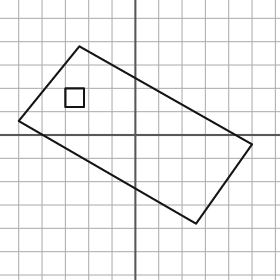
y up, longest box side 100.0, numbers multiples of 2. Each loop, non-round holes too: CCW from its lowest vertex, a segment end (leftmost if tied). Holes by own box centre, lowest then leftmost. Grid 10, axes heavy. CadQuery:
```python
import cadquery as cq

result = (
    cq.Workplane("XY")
    .moveTo(26.0, -38.0)
    .lineTo(50.0, -4.0)
    .lineTo(-24.0, 38.0)
    .lineTo(-50.0, 6.0)
    .close()
    .moveTo(-30.0, 12.0)
    .lineTo(-22.0, 12.0)
    .lineTo(-22.0, 20.0)
    .lineTo(-30.0, 20.0)
    .close()
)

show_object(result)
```